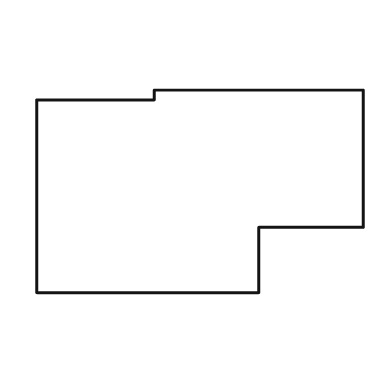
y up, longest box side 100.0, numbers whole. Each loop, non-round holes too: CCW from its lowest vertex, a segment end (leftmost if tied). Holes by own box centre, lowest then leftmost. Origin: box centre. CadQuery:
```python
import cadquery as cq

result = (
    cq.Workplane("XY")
    .moveTo(-50.0, -31.0)
    .lineTo(18.0, -31.0)
    .lineTo(18.0, -11.0)
    .lineTo(50.0, -11.0)
    .lineTo(50.0, 31.0)
    .lineTo(-14.0, 31.0)
    .lineTo(-14.0, 28.0)
    .lineTo(-50.0, 28.0)
    .close()
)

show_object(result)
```